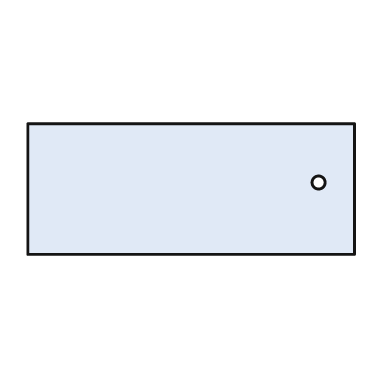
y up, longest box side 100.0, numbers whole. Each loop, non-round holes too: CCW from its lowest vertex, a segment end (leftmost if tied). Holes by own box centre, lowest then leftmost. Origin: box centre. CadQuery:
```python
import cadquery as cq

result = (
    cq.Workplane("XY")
    .moveTo(-50.0, -20.0)
    .lineTo(50.0, -20.0)
    .lineTo(50.0, 20.0)
    .lineTo(-50.0, 20.0)
    .close()
    .moveTo(39.0, 2.0)
    .circle(2.0)
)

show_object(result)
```